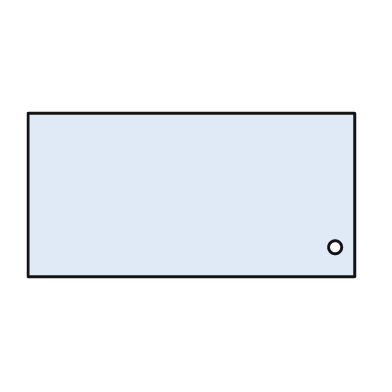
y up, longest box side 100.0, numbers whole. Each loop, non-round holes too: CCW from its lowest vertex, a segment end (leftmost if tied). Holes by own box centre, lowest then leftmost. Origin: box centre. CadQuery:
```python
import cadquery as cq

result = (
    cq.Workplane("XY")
    .moveTo(-50.0, -25.0)
    .lineTo(50.0, -25.0)
    .lineTo(50.0, 25.0)
    .lineTo(-50.0, 25.0)
    .close()
    .moveTo(44.0, -16.0)
    .circle(2.0)
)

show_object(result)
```